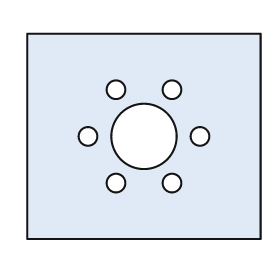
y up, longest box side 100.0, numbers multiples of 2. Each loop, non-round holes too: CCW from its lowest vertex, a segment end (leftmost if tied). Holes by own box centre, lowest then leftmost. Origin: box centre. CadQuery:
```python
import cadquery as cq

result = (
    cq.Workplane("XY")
    .moveTo(-50.0, -44.0)
    .lineTo(50.0, -44.0)
    .lineTo(50.0, 44.0)
    .lineTo(-50.0, 44.0)
    .close()
    .moveTo(-12.0, -20.0)
    .circle(4.0)
    .moveTo(12.0, -20.0)
    .circle(4.0)
    .moveTo(-24.0, 0.0)
    .circle(4.0)
    .moveTo(0.0, 0.0)
    .circle(14.0)
    .moveTo(24.0, 0.0)
    .circle(4.0)
    .moveTo(-12.0, 20.0)
    .circle(4.0)
    .moveTo(12.0, 20.0)
    .circle(4.0)
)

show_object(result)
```